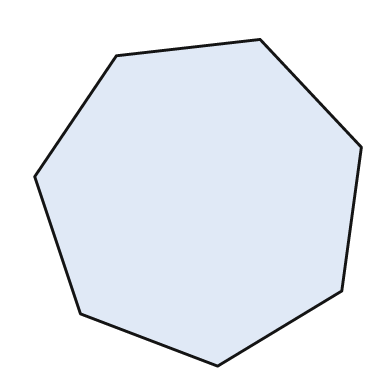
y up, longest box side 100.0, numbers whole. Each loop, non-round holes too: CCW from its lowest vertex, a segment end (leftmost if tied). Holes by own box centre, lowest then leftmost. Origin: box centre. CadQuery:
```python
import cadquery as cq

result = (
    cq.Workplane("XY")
    .moveTo(6.0, -50.0)
    .lineTo(44.0, -27.0)
    .lineTo(50.0, 17.0)
    .lineTo(19.0, 50.0)
    .lineTo(-25.0, 45.0)
    .lineTo(-50.0, 8.0)
    .lineTo(-36.0, -34.0)
    .close()
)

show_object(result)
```